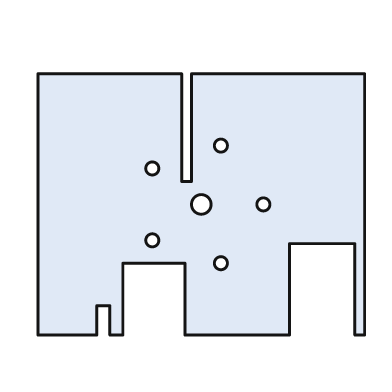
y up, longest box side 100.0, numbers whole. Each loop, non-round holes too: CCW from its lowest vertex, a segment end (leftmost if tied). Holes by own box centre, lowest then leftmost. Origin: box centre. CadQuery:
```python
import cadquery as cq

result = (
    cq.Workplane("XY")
    .moveTo(-50.0, -40.0)
    .lineTo(-32.0, -40.0)
    .lineTo(-32.0, -31.0)
    .lineTo(-28.0, -31.0)
    .lineTo(-28.0, -40.0)
    .lineTo(-24.0, -40.0)
    .lineTo(-24.0, -18.0)
    .lineTo(-5.0, -18.0)
    .lineTo(-5.0, -40.0)
    .lineTo(27.0, -40.0)
    .lineTo(27.0, -12.0)
    .lineTo(47.0, -12.0)
    .lineTo(47.0, -40.0)
    .lineTo(50.0, -40.0)
    .lineTo(50.0, 40.0)
    .lineTo(-3.0, 40.0)
    .lineTo(-3.0, 7.0)
    .lineTo(-6.0, 7.0)
    .lineTo(-6.0, 40.0)
    .lineTo(-50.0, 40.0)
    .close()
    .moveTo(6.0, -18.0)
    .circle(2.0)
    .moveTo(-15.0, -11.0)
    .circle(2.0)
    .moveTo(0.0, 0.0)
    .circle(3.0)
    .moveTo(19.0, 0.0)
    .circle(2.0)
    .moveTo(-15.0, 11.0)
    .circle(2.0)
    .moveTo(6.0, 18.0)
    .circle(2.0)
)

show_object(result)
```